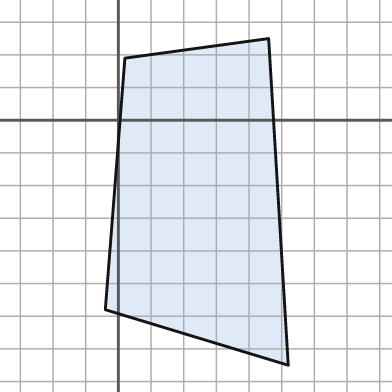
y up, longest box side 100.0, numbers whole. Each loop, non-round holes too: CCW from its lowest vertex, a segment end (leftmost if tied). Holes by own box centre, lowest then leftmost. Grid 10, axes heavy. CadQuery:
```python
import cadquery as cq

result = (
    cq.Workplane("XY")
    .moveTo(52.0, -75.0)
    .lineTo(46.0, 25.0)
    .lineTo(2.0, 19.0)
    .lineTo(-4.0, -58.0)
    .close()
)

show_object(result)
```